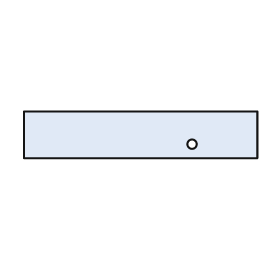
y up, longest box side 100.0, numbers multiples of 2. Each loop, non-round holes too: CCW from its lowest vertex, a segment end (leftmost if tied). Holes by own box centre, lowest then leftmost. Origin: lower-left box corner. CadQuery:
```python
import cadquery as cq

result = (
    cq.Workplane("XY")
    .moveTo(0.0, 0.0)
    .lineTo(100.0, 0.0)
    .lineTo(100.0, 20.0)
    .lineTo(0.0, 20.0)
    .close()
    .moveTo(72.0, 6.0)
    .circle(2.0)
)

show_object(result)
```